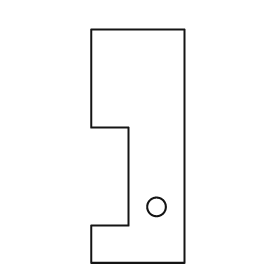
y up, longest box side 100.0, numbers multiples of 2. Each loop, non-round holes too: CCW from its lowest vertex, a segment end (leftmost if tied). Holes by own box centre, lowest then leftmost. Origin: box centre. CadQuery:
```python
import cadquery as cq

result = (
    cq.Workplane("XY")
    .moveTo(-20.0, -50.0)
    .lineTo(20.0, -50.0)
    .lineTo(20.0, 50.0)
    .lineTo(-20.0, 50.0)
    .lineTo(-20.0, 8.0)
    .lineTo(-4.0, 8.0)
    .lineTo(-4.0, -34.0)
    .lineTo(-20.0, -34.0)
    .close()
    .moveTo(8.0, -26.0)
    .circle(4.0)
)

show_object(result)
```